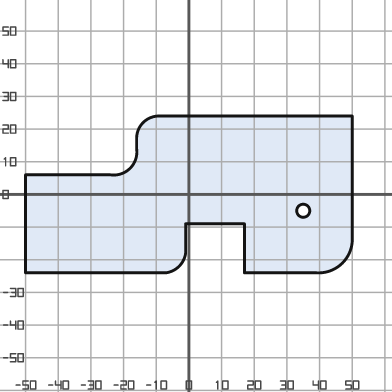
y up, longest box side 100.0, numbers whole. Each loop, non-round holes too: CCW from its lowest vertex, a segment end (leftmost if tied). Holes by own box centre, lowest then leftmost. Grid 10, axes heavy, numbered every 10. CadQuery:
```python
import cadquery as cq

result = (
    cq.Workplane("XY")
    .moveTo(-50.0, -24.0)
    .lineTo(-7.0, -24.0)
    .threePointArc((-3.0, -22.0), (-1.0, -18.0))
    .lineTo(-1.0, -9.0)
    .lineTo(17.0, -9.0)
    .lineTo(17.0, -24.0)
    .lineTo(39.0, -24.0)
    .threePointArc((47.0, -21.0), (50.0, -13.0))
    .lineTo(50.0, 24.0)
    .lineTo(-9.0, 24.0)
    .threePointArc((-14.0, 22.0), (-16.0, 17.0))
    .lineTo(-16.0, 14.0)
    .threePointArc((-18.0, 8.0), (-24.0, 6.0))
    .lineTo(-50.0, 6.0)
    .close()
    .moveTo(35.0, -5.0)
    .circle(2.0)
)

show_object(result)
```